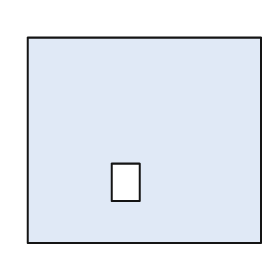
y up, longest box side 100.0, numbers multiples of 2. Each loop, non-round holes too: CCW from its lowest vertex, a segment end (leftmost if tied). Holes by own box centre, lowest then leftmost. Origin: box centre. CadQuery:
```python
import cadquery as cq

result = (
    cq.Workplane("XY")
    .moveTo(-50.0, -44.0)
    .lineTo(50.0, -44.0)
    .lineTo(50.0, 44.0)
    .lineTo(-50.0, 44.0)
    .close()
    .moveTo(-14.0, -26.0)
    .lineTo(-2.0, -26.0)
    .lineTo(-2.0, -10.0)
    .lineTo(-14.0, -10.0)
    .close()
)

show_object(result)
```